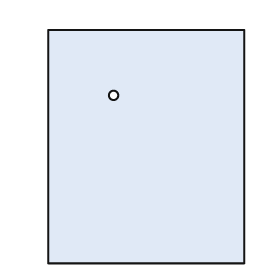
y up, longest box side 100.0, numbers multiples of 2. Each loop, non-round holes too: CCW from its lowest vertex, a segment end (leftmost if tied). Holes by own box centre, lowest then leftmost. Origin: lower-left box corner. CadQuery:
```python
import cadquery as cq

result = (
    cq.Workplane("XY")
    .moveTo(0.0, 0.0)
    .lineTo(84.0, 0.0)
    .lineTo(84.0, 100.0)
    .lineTo(0.0, 100.0)
    .close()
    .moveTo(28.0, 72.0)
    .circle(2.0)
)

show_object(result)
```